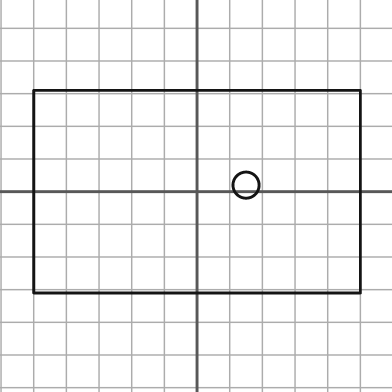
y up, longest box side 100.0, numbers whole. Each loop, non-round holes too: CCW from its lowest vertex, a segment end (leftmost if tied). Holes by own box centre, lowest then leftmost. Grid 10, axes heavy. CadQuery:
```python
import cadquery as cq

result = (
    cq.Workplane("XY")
    .moveTo(-50.0, -31.0)
    .lineTo(50.0, -31.0)
    .lineTo(50.0, 31.0)
    .lineTo(-50.0, 31.0)
    .close()
    .moveTo(15.0, 2.0)
    .circle(4.0)
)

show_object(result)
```